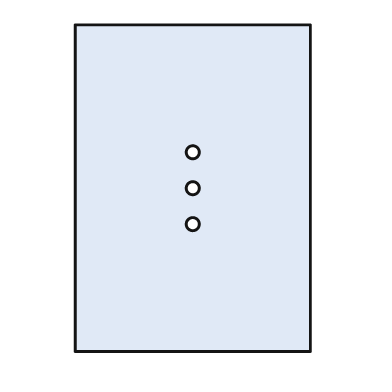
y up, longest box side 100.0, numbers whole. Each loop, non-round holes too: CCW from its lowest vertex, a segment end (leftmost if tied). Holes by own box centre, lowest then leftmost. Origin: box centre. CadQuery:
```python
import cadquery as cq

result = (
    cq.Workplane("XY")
    .moveTo(-36.0, -50.0)
    .lineTo(36.0, -50.0)
    .lineTo(36.0, 50.0)
    .lineTo(-36.0, 50.0)
    .close()
    .moveTo(0.0, -11.0)
    .circle(2.0)
    .moveTo(0.0, 0.0)
    .circle(2.0)
    .moveTo(0.0, 11.0)
    .circle(2.0)
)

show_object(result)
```